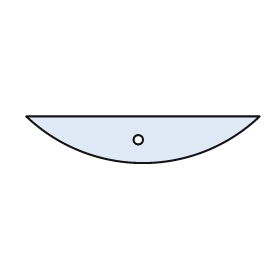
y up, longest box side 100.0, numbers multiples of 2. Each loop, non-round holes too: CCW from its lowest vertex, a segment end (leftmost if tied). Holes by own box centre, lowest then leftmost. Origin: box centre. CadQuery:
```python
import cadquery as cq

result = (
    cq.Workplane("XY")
    .moveTo(-50.0, 10.0)
    .threePointArc((0.0, -10.0), (50.0, 10.0))
    .close()
    .moveTo(-2.0, 0.0)
    .circle(2.0)
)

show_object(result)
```